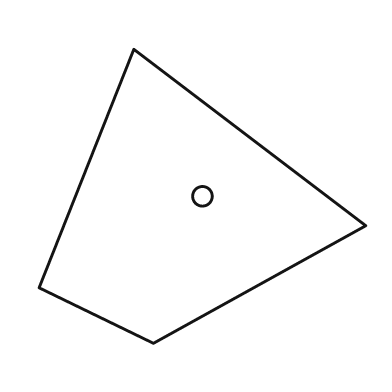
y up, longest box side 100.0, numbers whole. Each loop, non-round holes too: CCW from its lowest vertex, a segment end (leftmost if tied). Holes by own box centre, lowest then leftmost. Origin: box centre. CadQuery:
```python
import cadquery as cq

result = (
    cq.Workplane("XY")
    .moveTo(-15.0, -45.0)
    .lineTo(50.0, -9.0)
    .lineTo(-21.0, 45.0)
    .lineTo(-50.0, -28.0)
    .close()
    .moveTo(0.0, 0.0)
    .circle(3.0)
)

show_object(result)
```